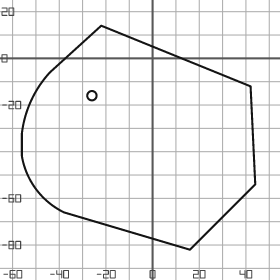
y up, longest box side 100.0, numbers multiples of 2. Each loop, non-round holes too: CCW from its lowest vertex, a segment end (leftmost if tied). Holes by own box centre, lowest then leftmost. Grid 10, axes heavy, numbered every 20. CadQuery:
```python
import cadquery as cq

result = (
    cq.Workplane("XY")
    .moveTo(16.0, -82.0)
    .lineTo(44.0, -54.0)
    .lineTo(42.0, -12.0)
    .lineTo(-22.0, 14.0)
    .lineTo(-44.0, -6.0)
    .threePointArc((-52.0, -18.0), (-56.0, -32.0))
    .lineTo(-56.0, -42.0)
    .threePointArc((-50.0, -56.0), (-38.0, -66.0))
    .close()
    .moveTo(-26.0, -16.0)
    .circle(2.0)
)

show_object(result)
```